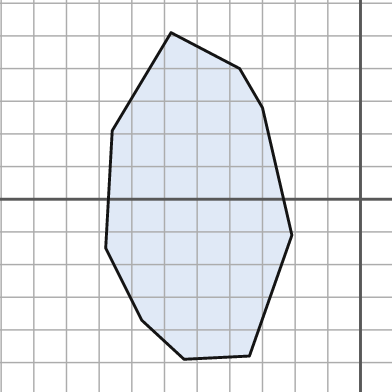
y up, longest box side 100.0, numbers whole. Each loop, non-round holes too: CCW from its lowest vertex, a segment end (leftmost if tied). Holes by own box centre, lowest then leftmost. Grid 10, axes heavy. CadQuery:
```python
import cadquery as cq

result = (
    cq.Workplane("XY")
    .moveTo(-54.0, -49.0)
    .lineTo(-34.0, -48.0)
    .lineTo(-21.0, -11.0)
    .lineTo(-30.0, 28.0)
    .lineTo(-37.0, 40.0)
    .lineTo(-58.0, 51.0)
    .lineTo(-76.0, 21.0)
    .lineTo(-78.0, -15.0)
    .lineTo(-67.0, -37.0)
    .close()
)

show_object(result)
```